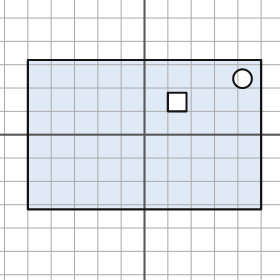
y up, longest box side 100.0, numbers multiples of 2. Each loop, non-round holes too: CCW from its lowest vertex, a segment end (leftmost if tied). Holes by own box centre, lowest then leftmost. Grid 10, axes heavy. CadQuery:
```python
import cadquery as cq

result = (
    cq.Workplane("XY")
    .moveTo(-50.0, -32.0)
    .lineTo(50.0, -32.0)
    .lineTo(50.0, 32.0)
    .lineTo(-50.0, 32.0)
    .close()
    .moveTo(10.0, 10.0)
    .lineTo(18.0, 10.0)
    .lineTo(18.0, 18.0)
    .lineTo(10.0, 18.0)
    .close()
    .moveTo(42.0, 24.0)
    .circle(4.0)
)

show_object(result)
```